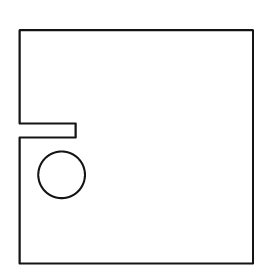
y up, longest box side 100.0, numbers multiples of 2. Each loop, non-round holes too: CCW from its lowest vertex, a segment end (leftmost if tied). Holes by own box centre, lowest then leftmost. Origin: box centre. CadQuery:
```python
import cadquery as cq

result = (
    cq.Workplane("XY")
    .moveTo(-50.0, -50.0)
    .lineTo(50.0, -50.0)
    .lineTo(50.0, 50.0)
    .lineTo(-50.0, 50.0)
    .lineTo(-50.0, 10.0)
    .lineTo(-26.0, 10.0)
    .lineTo(-26.0, 4.0)
    .lineTo(-50.0, 4.0)
    .close()
    .moveTo(-32.0, -12.0)
    .circle(10.0)
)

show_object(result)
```